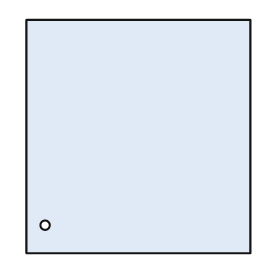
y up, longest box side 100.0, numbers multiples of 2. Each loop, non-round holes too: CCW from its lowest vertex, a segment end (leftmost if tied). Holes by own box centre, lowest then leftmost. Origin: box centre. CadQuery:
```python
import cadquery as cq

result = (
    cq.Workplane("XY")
    .moveTo(-48.0, -50.0)
    .lineTo(48.0, -50.0)
    .lineTo(48.0, 50.0)
    .lineTo(-48.0, 50.0)
    .close()
    .moveTo(-40.0, -38.0)
    .circle(2.0)
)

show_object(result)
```